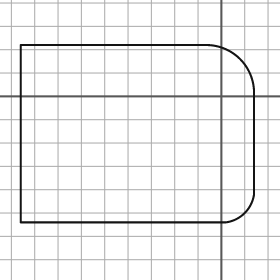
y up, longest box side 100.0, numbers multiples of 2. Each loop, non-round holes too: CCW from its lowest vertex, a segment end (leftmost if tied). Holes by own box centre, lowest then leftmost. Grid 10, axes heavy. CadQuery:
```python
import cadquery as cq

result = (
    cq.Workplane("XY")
    .moveTo(-86.0, -54.0)
    .lineTo(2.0, -54.0)
    .threePointArc((10.0, -50.0), (14.0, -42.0))
    .lineTo(14.0, 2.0)
    .threePointArc((8.0, 16.0), (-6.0, 22.0))
    .lineTo(-86.0, 22.0)
    .close()
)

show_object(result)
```